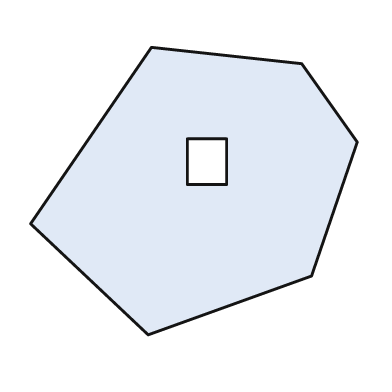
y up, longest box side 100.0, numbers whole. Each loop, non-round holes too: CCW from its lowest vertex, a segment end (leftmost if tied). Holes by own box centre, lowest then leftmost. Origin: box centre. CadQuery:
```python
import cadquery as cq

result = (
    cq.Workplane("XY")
    .moveTo(-14.0, -44.0)
    .lineTo(36.0, -26.0)
    .lineTo(50.0, 15.0)
    .lineTo(33.0, 39.0)
    .lineTo(-13.0, 44.0)
    .lineTo(-50.0, -10.0)
    .close()
    .moveTo(-2.0, 2.0)
    .lineTo(10.0, 2.0)
    .lineTo(10.0, 16.0)
    .lineTo(-2.0, 16.0)
    .close()
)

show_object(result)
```